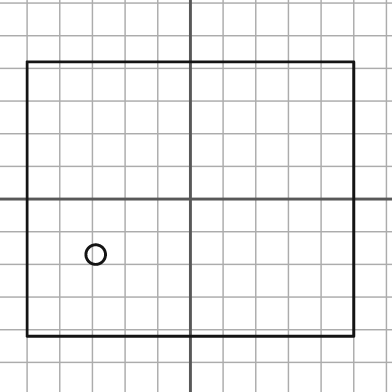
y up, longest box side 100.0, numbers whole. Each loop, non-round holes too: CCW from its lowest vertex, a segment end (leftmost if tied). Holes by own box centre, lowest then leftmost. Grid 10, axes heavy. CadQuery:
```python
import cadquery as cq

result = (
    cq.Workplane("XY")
    .moveTo(-50.0, -42.0)
    .lineTo(50.0, -42.0)
    .lineTo(50.0, 42.0)
    .lineTo(-50.0, 42.0)
    .close()
    .moveTo(-29.0, -17.0)
    .circle(3.0)
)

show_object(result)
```